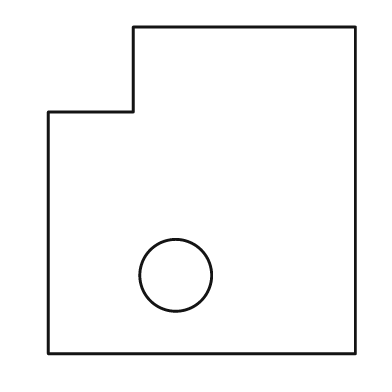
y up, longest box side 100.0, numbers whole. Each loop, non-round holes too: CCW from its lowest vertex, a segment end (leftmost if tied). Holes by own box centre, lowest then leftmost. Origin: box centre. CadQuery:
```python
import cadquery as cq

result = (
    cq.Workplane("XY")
    .moveTo(-47.0, -50.0)
    .lineTo(47.0, -50.0)
    .lineTo(47.0, 50.0)
    .lineTo(-21.0, 50.0)
    .lineTo(-21.0, 24.0)
    .lineTo(-47.0, 24.0)
    .close()
    .moveTo(-8.0, -26.0)
    .circle(11.0)
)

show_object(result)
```